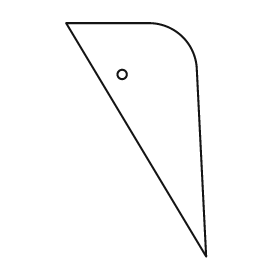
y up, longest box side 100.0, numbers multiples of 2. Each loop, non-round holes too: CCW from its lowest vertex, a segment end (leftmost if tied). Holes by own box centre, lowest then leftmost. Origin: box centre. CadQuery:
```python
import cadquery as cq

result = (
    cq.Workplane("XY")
    .moveTo(30.0, -50.0)
    .lineTo(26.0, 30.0)
    .threePointArc((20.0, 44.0), (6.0, 50.0))
    .lineTo(-30.0, 50.0)
    .close()
    .moveTo(-6.0, 28.0)
    .circle(2.0)
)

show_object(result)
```